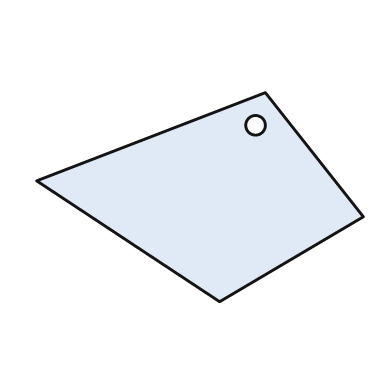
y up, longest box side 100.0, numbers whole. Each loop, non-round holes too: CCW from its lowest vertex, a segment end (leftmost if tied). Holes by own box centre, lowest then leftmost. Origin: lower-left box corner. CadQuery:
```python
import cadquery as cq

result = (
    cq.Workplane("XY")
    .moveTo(56.0, 0.0)
    .lineTo(100.0, 26.0)
    .lineTo(70.0, 64.0)
    .lineTo(0.0, 37.0)
    .close()
    .moveTo(67.0, 54.0)
    .circle(3.0)
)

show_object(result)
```